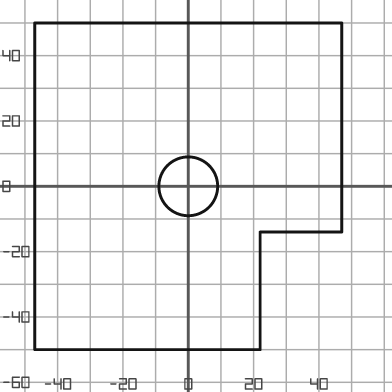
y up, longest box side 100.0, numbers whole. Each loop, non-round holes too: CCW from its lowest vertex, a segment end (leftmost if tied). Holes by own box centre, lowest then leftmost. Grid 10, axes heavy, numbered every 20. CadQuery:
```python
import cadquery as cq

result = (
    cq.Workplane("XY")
    .moveTo(-47.0, -50.0)
    .lineTo(22.0, -50.0)
    .lineTo(22.0, -14.0)
    .lineTo(47.0, -14.0)
    .lineTo(47.0, 50.0)
    .lineTo(-47.0, 50.0)
    .close()
    .moveTo(0.0, 0.0)
    .circle(9.0)
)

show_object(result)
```